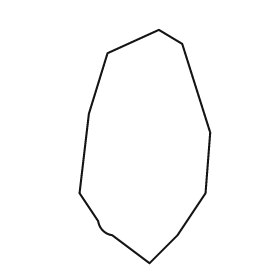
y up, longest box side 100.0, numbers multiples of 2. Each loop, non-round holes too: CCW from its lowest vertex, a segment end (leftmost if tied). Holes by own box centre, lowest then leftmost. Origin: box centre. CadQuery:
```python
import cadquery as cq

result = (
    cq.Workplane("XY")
    .moveTo(2.0, -50.0)
    .lineTo(14.0, -38.0)
    .lineTo(26.0, -20.0)
    .lineTo(28.0, 6.0)
    .lineTo(16.0, 44.0)
    .lineTo(6.0, 50.0)
    .lineTo(-16.0, 40.0)
    .lineTo(-24.0, 14.0)
    .lineTo(-28.0, -20.0)
    .lineTo(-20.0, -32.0)
    .threePointArc((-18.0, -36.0), (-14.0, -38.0))
    .close()
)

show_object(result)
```